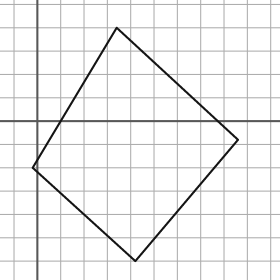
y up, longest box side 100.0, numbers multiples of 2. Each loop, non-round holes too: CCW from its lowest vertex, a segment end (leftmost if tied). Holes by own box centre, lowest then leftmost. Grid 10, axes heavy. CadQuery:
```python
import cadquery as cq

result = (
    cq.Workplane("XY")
    .moveTo(42.0, -60.0)
    .lineTo(86.0, -8.0)
    .lineTo(34.0, 40.0)
    .lineTo(-2.0, -20.0)
    .close()
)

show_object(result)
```